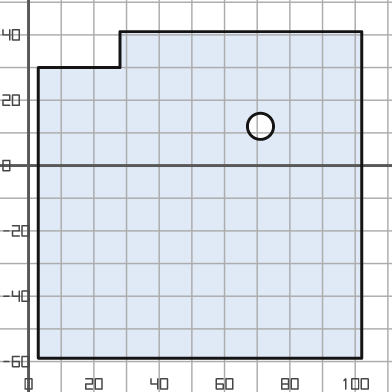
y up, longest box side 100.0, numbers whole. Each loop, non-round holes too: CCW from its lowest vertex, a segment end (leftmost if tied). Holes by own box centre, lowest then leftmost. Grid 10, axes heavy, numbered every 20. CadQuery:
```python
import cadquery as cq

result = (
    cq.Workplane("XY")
    .moveTo(3.0, -59.0)
    .lineTo(102.0, -59.0)
    .lineTo(102.0, 41.0)
    .lineTo(28.0, 41.0)
    .lineTo(28.0, 30.0)
    .lineTo(3.0, 30.0)
    .close()
    .moveTo(71.0, 12.0)
    .circle(4.0)
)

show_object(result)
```